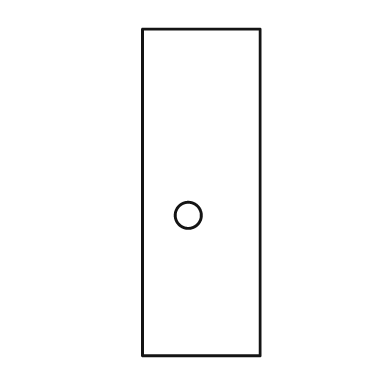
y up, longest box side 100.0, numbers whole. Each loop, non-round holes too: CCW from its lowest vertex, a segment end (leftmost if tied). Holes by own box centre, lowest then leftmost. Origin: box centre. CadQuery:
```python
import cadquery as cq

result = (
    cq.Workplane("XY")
    .moveTo(-18.0, -50.0)
    .lineTo(18.0, -50.0)
    .lineTo(18.0, 50.0)
    .lineTo(-18.0, 50.0)
    .close()
    .moveTo(-4.0, -7.0)
    .circle(4.0)
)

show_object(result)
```